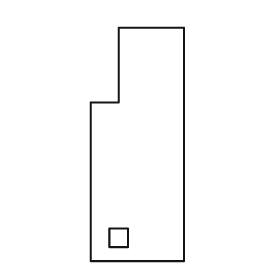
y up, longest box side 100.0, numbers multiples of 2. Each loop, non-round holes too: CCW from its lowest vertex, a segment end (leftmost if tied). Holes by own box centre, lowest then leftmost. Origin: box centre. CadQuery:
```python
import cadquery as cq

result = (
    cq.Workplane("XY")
    .moveTo(-20.0, -50.0)
    .lineTo(20.0, -50.0)
    .lineTo(20.0, 50.0)
    .lineTo(-8.0, 50.0)
    .lineTo(-8.0, 18.0)
    .lineTo(-20.0, 18.0)
    .close()
    .moveTo(-12.0, -44.0)
    .lineTo(-4.0, -44.0)
    .lineTo(-4.0, -36.0)
    .lineTo(-12.0, -36.0)
    .close()
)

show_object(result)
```